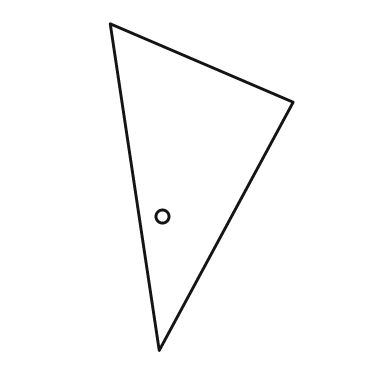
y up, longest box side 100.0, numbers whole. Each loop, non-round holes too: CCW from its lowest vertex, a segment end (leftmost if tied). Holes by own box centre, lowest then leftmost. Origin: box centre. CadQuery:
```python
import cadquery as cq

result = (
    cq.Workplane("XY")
    .moveTo(-13.0, -50.0)
    .lineTo(28.0, 26.0)
    .lineTo(-28.0, 50.0)
    .close()
    .moveTo(-12.0, -9.0)
    .circle(2.0)
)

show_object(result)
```